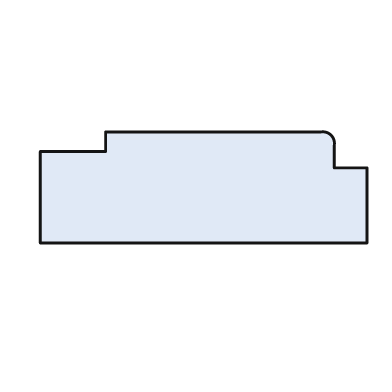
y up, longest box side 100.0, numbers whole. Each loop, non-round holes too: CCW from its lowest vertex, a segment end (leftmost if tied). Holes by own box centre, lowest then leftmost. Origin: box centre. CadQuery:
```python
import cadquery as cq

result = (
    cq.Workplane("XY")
    .moveTo(-50.0, -17.0)
    .lineTo(50.0, -17.0)
    .lineTo(50.0, 6.0)
    .lineTo(40.0, 6.0)
    .lineTo(40.0, 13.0)
    .threePointArc((39.0, 16.0), (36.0, 17.0))
    .lineTo(-30.0, 17.0)
    .lineTo(-30.0, 11.0)
    .lineTo(-50.0, 11.0)
    .close()
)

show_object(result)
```